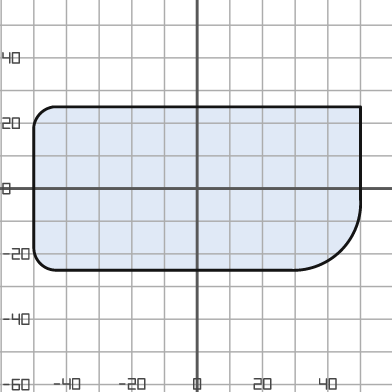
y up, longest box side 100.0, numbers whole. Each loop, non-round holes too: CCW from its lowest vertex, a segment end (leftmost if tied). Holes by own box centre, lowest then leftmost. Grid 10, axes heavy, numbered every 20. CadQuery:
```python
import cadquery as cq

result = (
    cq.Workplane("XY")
    .moveTo(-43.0, -25.0)
    .lineTo(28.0, -25.0)
    .threePointArc((44.0, -19.0), (50.0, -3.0))
    .lineTo(50.0, 25.0)
    .lineTo(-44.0, 25.0)
    .threePointArc((-48.0, 23.0), (-50.0, 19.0))
    .lineTo(-50.0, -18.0)
    .threePointArc((-48.0, -23.0), (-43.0, -25.0))
    .close()
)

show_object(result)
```